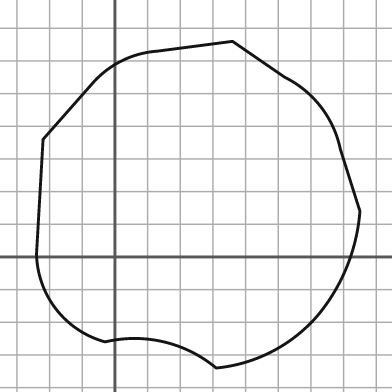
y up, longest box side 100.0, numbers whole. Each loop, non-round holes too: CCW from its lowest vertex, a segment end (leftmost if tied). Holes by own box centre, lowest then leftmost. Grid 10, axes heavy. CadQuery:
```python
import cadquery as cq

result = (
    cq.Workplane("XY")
    .moveTo(31.0, -34.0)
    .threePointArc((48.0, -29.0), (62.0, -18.0))
    .threePointArc((71.0, -3.0), (75.0, 14.0))
    .lineTo(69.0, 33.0)
    .threePointArc((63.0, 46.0), (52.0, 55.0))
    .lineTo(36.0, 66.0)
    .lineTo(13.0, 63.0)
    .threePointArc((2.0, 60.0), (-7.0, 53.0))
    .lineTo(-22.0, 36.0)
    .lineTo(-24.0, 1.0)
    .threePointArc((-18.0, -16.0), (-3.0, -26.0))
    .threePointArc((15.0, -26.0), (31.0, -34.0))
    .close()
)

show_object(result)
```